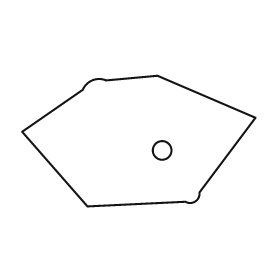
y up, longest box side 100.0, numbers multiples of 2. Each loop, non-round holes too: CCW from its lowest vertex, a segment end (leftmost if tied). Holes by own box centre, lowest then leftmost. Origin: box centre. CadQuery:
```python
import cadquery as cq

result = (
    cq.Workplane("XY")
    .moveTo(-22.0, -28.0)
    .lineTo(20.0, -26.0)
    .threePointArc((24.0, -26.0), (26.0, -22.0))
    .lineTo(50.0, 10.0)
    .lineTo(8.0, 28.0)
    .lineTo(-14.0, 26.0)
    .threePointArc((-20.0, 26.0), (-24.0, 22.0))
    .lineTo(-50.0, 4.0)
    .close()
    .moveTo(10.0, -4.0)
    .circle(4.0)
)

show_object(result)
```